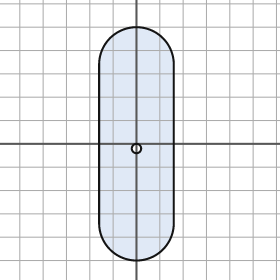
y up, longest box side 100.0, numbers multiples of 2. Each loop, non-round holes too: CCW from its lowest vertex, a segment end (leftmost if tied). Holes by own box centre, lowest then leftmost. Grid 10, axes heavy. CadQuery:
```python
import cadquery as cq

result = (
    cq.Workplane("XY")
    .moveTo(-16.0, -34.0)
    .threePointArc((0.0, -50.0), (16.0, -34.0))
    .lineTo(16.0, 34.0)
    .threePointArc((0.0, 50.0), (-16.0, 34.0))
    .close()
    .moveTo(0.0, -2.0)
    .circle(2.0)
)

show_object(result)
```